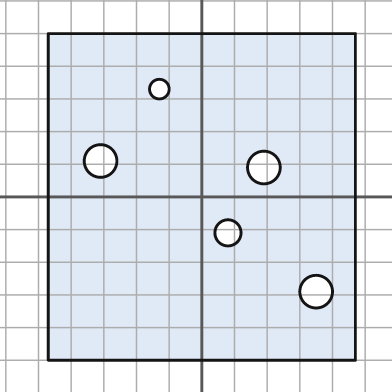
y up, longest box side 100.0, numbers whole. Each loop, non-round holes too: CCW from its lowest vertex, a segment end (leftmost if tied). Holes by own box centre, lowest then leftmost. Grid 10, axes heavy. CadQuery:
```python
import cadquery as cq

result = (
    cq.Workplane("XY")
    .moveTo(-47.0, -50.0)
    .lineTo(47.0, -50.0)
    .lineTo(47.0, 50.0)
    .lineTo(-47.0, 50.0)
    .close()
    .moveTo(35.0, -29.0)
    .circle(5.0)
    .moveTo(8.0, -11.0)
    .circle(4.0)
    .moveTo(19.0, 9.0)
    .circle(5.0)
    .moveTo(-31.0, 11.0)
    .circle(5.0)
    .moveTo(-13.0, 33.0)
    .circle(3.0)
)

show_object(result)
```